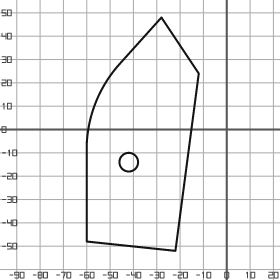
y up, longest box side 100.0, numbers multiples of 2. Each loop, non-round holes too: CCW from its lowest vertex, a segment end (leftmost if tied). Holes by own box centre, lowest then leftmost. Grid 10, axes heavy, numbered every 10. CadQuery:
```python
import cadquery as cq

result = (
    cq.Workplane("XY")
    .moveTo(-22.0, -52.0)
    .lineTo(-12.0, 24.0)
    .lineTo(-28.0, 48.0)
    .lineTo(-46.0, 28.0)
    .threePointArc((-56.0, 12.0), (-60.0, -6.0))
    .lineTo(-60.0, -48.0)
    .close()
    .moveTo(-42.0, -14.0)
    .circle(4.0)
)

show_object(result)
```